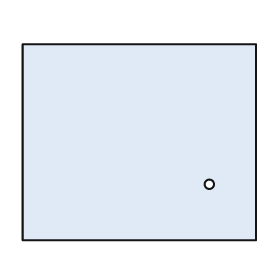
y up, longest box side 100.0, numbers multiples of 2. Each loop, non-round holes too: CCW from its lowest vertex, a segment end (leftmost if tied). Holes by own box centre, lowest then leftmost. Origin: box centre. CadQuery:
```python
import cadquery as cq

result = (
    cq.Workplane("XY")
    .moveTo(-50.0, -42.0)
    .lineTo(50.0, -42.0)
    .lineTo(50.0, 42.0)
    .lineTo(-50.0, 42.0)
    .close()
    .moveTo(30.0, -18.0)
    .circle(2.0)
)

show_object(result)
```